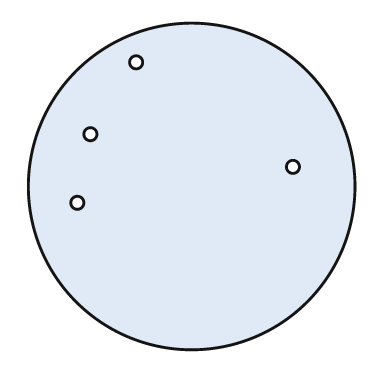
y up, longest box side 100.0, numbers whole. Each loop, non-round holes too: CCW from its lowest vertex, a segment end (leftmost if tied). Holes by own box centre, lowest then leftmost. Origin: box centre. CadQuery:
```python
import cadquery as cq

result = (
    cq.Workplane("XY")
    .moveTo(0.0, 0.0)
    .circle(50.0)
    .moveTo(-35.0, -5.0)
    .circle(2.0)
    .moveTo(31.0, 6.0)
    .circle(2.0)
    .moveTo(-31.0, 16.0)
    .circle(2.0)
    .moveTo(-17.0, 38.0)
    .circle(2.0)
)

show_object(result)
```